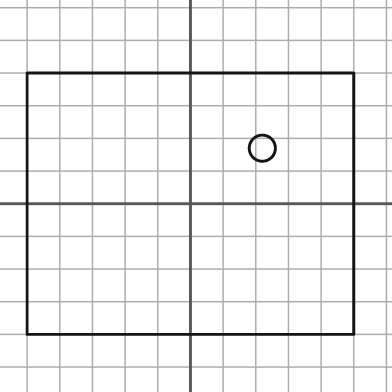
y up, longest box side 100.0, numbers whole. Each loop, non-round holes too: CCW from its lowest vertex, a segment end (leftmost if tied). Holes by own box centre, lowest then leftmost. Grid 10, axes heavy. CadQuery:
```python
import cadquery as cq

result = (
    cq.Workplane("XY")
    .moveTo(-50.0, -40.0)
    .lineTo(50.0, -40.0)
    .lineTo(50.0, 40.0)
    .lineTo(-50.0, 40.0)
    .close()
    .moveTo(22.0, 17.0)
    .circle(4.0)
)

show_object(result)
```